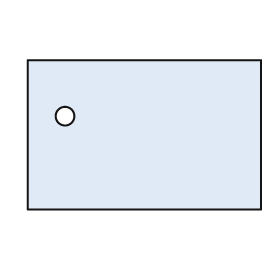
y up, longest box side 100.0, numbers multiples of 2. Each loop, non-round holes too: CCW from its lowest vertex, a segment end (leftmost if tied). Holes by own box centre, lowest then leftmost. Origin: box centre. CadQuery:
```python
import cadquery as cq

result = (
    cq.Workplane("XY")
    .moveTo(-50.0, -32.0)
    .lineTo(50.0, -32.0)
    .lineTo(50.0, 32.0)
    .lineTo(-50.0, 32.0)
    .close()
    .moveTo(-34.0, 8.0)
    .circle(4.0)
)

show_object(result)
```